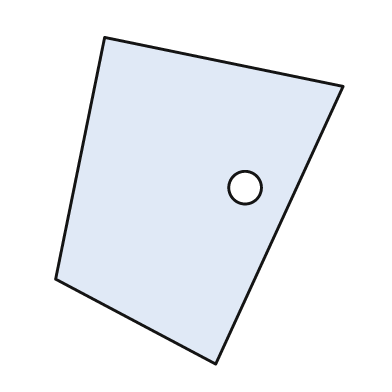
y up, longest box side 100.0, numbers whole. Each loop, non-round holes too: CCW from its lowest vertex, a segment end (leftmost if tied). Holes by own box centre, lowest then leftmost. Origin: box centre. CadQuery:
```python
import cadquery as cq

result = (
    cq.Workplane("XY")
    .moveTo(5.0, -50.0)
    .lineTo(44.0, 35.0)
    .lineTo(-29.0, 50.0)
    .lineTo(-44.0, -24.0)
    .close()
    .moveTo(14.0, 4.0)
    .circle(5.0)
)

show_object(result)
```